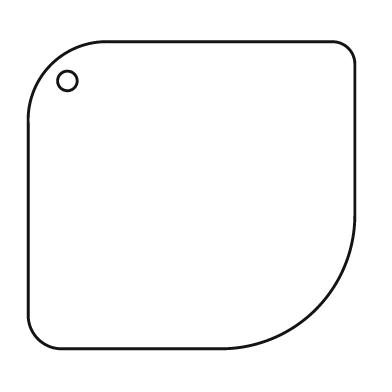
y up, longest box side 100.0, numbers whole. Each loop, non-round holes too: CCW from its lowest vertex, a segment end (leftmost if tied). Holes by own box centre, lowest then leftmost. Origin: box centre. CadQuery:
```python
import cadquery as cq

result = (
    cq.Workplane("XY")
    .moveTo(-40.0, -47.0)
    .lineTo(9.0, -47.0)
    .threePointArc((38.0, -35.0), (50.0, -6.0))
    .lineTo(50.0, 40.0)
    .threePointArc((48.0, 45.0), (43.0, 47.0))
    .lineTo(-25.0, 47.0)
    .threePointArc((-43.0, 40.0), (-50.0, 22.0))
    .lineTo(-50.0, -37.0)
    .threePointArc((-47.0, -44.0), (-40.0, -47.0))
    .close()
    .moveTo(-38.0, 35.0)
    .circle(3.0)
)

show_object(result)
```